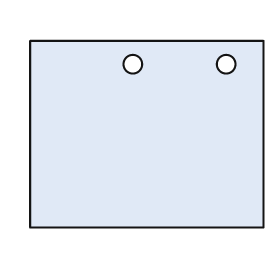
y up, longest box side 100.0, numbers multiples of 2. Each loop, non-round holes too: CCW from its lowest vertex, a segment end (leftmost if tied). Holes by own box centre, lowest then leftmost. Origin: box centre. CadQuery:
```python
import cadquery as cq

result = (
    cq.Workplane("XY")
    .moveTo(-50.0, -40.0)
    .lineTo(50.0, -40.0)
    .lineTo(50.0, 40.0)
    .lineTo(-50.0, 40.0)
    .close()
    .moveTo(-6.0, 30.0)
    .circle(4.0)
    .moveTo(34.0, 30.0)
    .circle(4.0)
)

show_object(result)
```